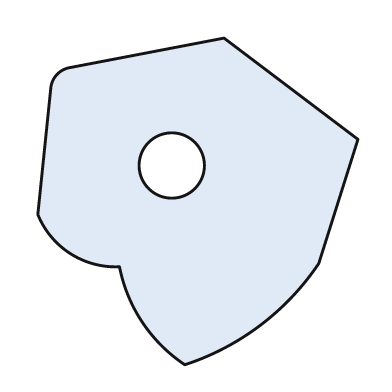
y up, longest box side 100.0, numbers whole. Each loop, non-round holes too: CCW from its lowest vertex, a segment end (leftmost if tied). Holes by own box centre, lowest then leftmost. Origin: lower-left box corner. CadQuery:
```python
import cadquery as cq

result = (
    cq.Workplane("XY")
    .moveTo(45.0, 0.0)
    .threePointArc((68.0, 12.0), (86.0, 31.0))
    .lineTo(98.0, 69.0)
    .lineTo(57.0, 100.0)
    .lineTo(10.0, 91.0)
    .threePointArc((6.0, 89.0), (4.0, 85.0))
    .lineTo(0.0, 46.0)
    .threePointArc((10.0, 34.0), (25.0, 30.0))
    .threePointArc((32.0, 13.0), (45.0, 0.0))
    .close()
    .moveTo(41.0, 61.0)
    .circle(10.0)
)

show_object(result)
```